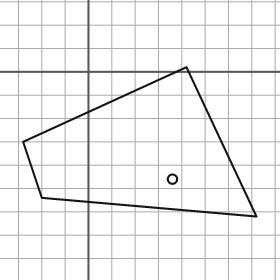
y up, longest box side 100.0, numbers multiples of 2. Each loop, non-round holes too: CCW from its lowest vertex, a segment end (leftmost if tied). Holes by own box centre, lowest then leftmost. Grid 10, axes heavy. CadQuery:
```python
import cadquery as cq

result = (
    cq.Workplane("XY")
    .moveTo(72.0, -62.0)
    .lineTo(42.0, 2.0)
    .lineTo(-28.0, -30.0)
    .lineTo(-20.0, -54.0)
    .close()
    .moveTo(36.0, -46.0)
    .circle(2.0)
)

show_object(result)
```